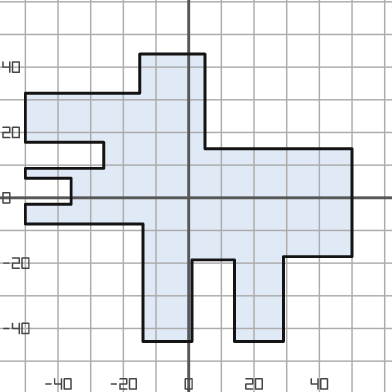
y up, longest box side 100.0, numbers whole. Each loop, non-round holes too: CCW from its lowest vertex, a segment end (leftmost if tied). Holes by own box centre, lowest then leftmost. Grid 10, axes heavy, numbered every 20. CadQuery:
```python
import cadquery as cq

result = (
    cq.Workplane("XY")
    .moveTo(-14.0, -44.0)
    .lineTo(1.0, -44.0)
    .lineTo(1.0, -19.0)
    .lineTo(14.0, -19.0)
    .lineTo(14.0, -44.0)
    .lineTo(29.0, -44.0)
    .lineTo(29.0, -18.0)
    .lineTo(50.0, -18.0)
    .lineTo(50.0, 15.0)
    .lineTo(5.0, 15.0)
    .lineTo(5.0, 44.0)
    .lineTo(-15.0, 44.0)
    .lineTo(-15.0, 32.0)
    .lineTo(-50.0, 32.0)
    .lineTo(-50.0, 17.0)
    .lineTo(-26.0, 17.0)
    .lineTo(-26.0, 9.0)
    .lineTo(-50.0, 9.0)
    .lineTo(-50.0, 6.0)
    .lineTo(-36.0, 6.0)
    .lineTo(-36.0, -2.0)
    .lineTo(-50.0, -2.0)
    .lineTo(-50.0, -8.0)
    .lineTo(-14.0, -8.0)
    .close()
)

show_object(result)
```